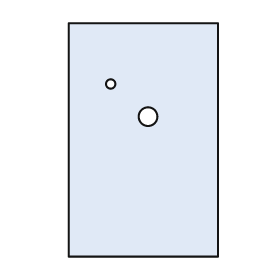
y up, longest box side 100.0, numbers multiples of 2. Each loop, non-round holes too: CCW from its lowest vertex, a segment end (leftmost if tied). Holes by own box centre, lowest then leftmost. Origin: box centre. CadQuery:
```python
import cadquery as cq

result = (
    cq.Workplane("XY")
    .moveTo(-32.0, -50.0)
    .lineTo(32.0, -50.0)
    .lineTo(32.0, 50.0)
    .lineTo(-32.0, 50.0)
    .close()
    .moveTo(2.0, 10.0)
    .circle(4.0)
    .moveTo(-14.0, 24.0)
    .circle(2.0)
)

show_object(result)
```